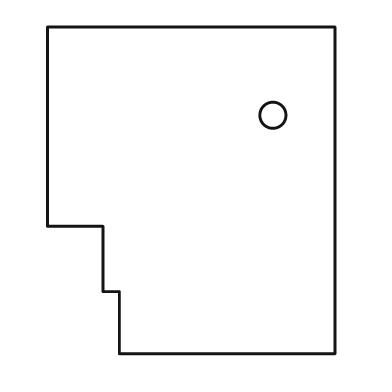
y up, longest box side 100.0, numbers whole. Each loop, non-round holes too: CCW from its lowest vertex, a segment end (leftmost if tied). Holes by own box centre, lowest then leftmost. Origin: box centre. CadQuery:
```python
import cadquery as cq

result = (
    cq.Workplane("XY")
    .moveTo(-22.0, -50.0)
    .lineTo(44.0, -50.0)
    .lineTo(44.0, 50.0)
    .lineTo(-44.0, 50.0)
    .lineTo(-44.0, -11.0)
    .lineTo(-27.0, -11.0)
    .lineTo(-27.0, -31.0)
    .lineTo(-22.0, -31.0)
    .close()
    .moveTo(25.0, 23.0)
    .circle(4.0)
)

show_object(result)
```